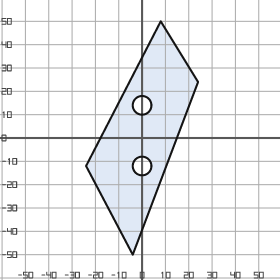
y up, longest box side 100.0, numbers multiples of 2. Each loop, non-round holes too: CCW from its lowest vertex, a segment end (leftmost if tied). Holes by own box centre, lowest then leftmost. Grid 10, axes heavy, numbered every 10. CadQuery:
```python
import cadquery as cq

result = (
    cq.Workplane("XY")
    .moveTo(-4.0, -50.0)
    .lineTo(24.0, 24.0)
    .lineTo(8.0, 50.0)
    .lineTo(-24.0, -12.0)
    .close()
    .moveTo(0.0, -12.0)
    .circle(4.0)
    .moveTo(0.0, 14.0)
    .circle(4.0)
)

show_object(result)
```